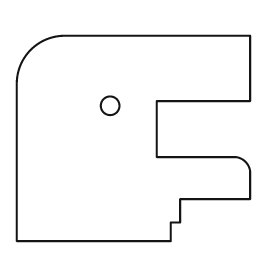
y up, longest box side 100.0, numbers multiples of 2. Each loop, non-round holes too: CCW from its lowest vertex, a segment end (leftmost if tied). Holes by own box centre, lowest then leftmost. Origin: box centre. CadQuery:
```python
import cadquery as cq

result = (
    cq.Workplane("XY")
    .moveTo(-50.0, -44.0)
    .lineTo(16.0, -44.0)
    .lineTo(16.0, -36.0)
    .lineTo(20.0, -36.0)
    .lineTo(20.0, -26.0)
    .lineTo(50.0, -26.0)
    .lineTo(50.0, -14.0)
    .threePointArc((48.0, -10.0), (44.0, -8.0))
    .lineTo(10.0, -8.0)
    .lineTo(10.0, 16.0)
    .lineTo(50.0, 16.0)
    .lineTo(50.0, 44.0)
    .lineTo(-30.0, 44.0)
    .threePointArc((-44.0, 38.0), (-50.0, 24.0))
    .close()
    .moveTo(-10.0, 14.0)
    .circle(4.0)
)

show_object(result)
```